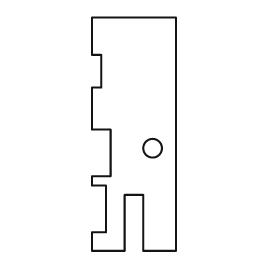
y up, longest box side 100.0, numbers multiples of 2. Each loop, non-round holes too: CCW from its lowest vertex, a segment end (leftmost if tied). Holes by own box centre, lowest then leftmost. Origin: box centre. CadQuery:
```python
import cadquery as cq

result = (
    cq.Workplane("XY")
    .moveTo(-18.0, -50.0)
    .lineTo(-4.0, -50.0)
    .lineTo(-4.0, -26.0)
    .lineTo(4.0, -26.0)
    .lineTo(4.0, -50.0)
    .lineTo(18.0, -50.0)
    .lineTo(18.0, 50.0)
    .lineTo(-18.0, 50.0)
    .lineTo(-18.0, 34.0)
    .lineTo(-14.0, 34.0)
    .lineTo(-14.0, 20.0)
    .lineTo(-18.0, 20.0)
    .lineTo(-18.0, 2.0)
    .lineTo(-10.0, 2.0)
    .lineTo(-10.0, -18.0)
    .lineTo(-18.0, -18.0)
    .lineTo(-18.0, -22.0)
    .lineTo(-12.0, -22.0)
    .lineTo(-12.0, -42.0)
    .lineTo(-18.0, -42.0)
    .close()
    .moveTo(8.0, -6.0)
    .circle(4.0)
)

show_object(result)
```